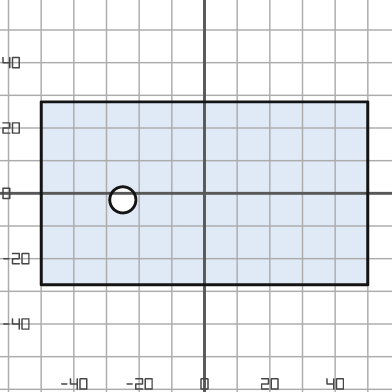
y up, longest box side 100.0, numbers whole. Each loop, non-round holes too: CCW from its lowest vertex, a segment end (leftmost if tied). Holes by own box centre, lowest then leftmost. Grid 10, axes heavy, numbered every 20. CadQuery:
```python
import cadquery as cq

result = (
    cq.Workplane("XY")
    .moveTo(-50.0, -28.0)
    .lineTo(50.0, -28.0)
    .lineTo(50.0, 28.0)
    .lineTo(-50.0, 28.0)
    .close()
    .moveTo(-25.0, -2.0)
    .circle(4.0)
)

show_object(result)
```